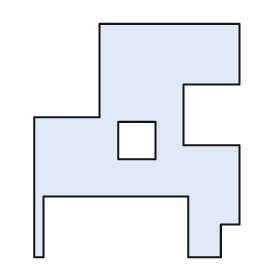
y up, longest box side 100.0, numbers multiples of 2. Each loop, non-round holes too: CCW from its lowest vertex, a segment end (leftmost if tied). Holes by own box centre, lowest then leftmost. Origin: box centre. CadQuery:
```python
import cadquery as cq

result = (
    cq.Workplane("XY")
    .moveTo(-44.0, -50.0)
    .lineTo(-40.0, -50.0)
    .lineTo(-40.0, -24.0)
    .lineTo(22.0, -24.0)
    .lineTo(22.0, -50.0)
    .lineTo(36.0, -50.0)
    .lineTo(36.0, -36.0)
    .lineTo(44.0, -36.0)
    .lineTo(44.0, -2.0)
    .lineTo(20.0, -2.0)
    .lineTo(20.0, 24.0)
    .lineTo(44.0, 24.0)
    .lineTo(44.0, 50.0)
    .lineTo(-16.0, 50.0)
    .lineTo(-16.0, 10.0)
    .lineTo(-44.0, 10.0)
    .close()
    .moveTo(-8.0, -8.0)
    .lineTo(8.0, -8.0)
    .lineTo(8.0, 8.0)
    .lineTo(-8.0, 8.0)
    .close()
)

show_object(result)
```